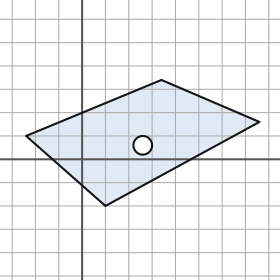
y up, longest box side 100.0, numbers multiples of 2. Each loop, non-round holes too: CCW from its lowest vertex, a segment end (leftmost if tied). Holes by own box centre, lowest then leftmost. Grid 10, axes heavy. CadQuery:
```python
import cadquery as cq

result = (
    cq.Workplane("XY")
    .moveTo(10.0, -20.0)
    .lineTo(76.0, 16.0)
    .lineTo(34.0, 34.0)
    .lineTo(-24.0, 10.0)
    .close()
    .moveTo(26.0, 6.0)
    .circle(4.0)
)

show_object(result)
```